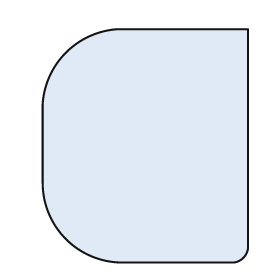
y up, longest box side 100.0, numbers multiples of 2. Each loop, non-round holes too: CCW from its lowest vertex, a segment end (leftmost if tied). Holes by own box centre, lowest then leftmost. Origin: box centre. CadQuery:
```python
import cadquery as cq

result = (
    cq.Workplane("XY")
    .moveTo(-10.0, -50.0)
    .lineTo(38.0, -50.0)
    .threePointArc((42.0, -48.0), (44.0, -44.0))
    .lineTo(44.0, 50.0)
    .lineTo(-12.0, 50.0)
    .threePointArc((-34.0, 40.0), (-44.0, 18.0))
    .lineTo(-44.0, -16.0)
    .threePointArc((-34.0, -40.0), (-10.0, -50.0))
    .close()
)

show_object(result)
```